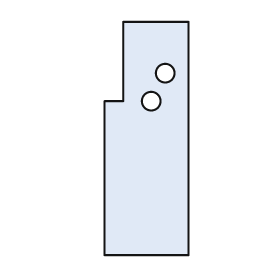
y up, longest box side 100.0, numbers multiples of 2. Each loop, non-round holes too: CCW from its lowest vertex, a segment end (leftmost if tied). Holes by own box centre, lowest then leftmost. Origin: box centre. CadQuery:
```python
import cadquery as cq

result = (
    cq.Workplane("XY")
    .moveTo(-18.0, -50.0)
    .lineTo(18.0, -50.0)
    .lineTo(18.0, 50.0)
    .lineTo(-10.0, 50.0)
    .lineTo(-10.0, 16.0)
    .lineTo(-18.0, 16.0)
    .close()
    .moveTo(2.0, 16.0)
    .circle(4.0)
    .moveTo(8.0, 28.0)
    .circle(4.0)
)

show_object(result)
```